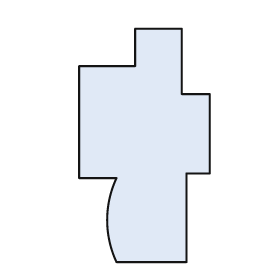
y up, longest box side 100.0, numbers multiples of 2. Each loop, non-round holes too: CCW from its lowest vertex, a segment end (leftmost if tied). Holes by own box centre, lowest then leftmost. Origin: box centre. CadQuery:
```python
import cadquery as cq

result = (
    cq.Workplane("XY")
    .moveTo(-12.0, -50.0)
    .lineTo(18.0, -50.0)
    .lineTo(18.0, -12.0)
    .lineTo(28.0, -12.0)
    .lineTo(28.0, 22.0)
    .lineTo(16.0, 22.0)
    .lineTo(16.0, 50.0)
    .lineTo(-4.0, 50.0)
    .lineTo(-4.0, 34.0)
    .lineTo(-28.0, 34.0)
    .lineTo(-28.0, -14.0)
    .lineTo(-12.0, -14.0)
    .threePointArc((-16.0, -32.0), (-12.0, -50.0))
    .close()
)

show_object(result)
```